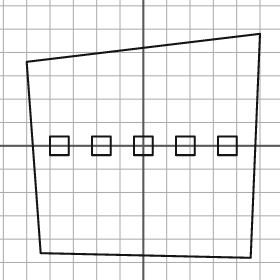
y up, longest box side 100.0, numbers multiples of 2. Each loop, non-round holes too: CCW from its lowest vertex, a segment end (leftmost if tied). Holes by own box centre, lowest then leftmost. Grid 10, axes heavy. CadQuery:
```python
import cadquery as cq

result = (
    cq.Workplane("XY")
    .moveTo(46.0, -48.0)
    .lineTo(50.0, 48.0)
    .lineTo(-50.0, 36.0)
    .lineTo(-44.0, -46.0)
    .close()
    .moveTo(-40.0, -4.0)
    .lineTo(-32.0, -4.0)
    .lineTo(-32.0, 4.0)
    .lineTo(-40.0, 4.0)
    .close()
    .moveTo(-22.0, -4.0)
    .lineTo(-14.0, -4.0)
    .lineTo(-14.0, 4.0)
    .lineTo(-22.0, 4.0)
    .close()
    .moveTo(-4.0, -4.0)
    .lineTo(4.0, -4.0)
    .lineTo(4.0, 4.0)
    .lineTo(-4.0, 4.0)
    .close()
    .moveTo(14.0, -4.0)
    .lineTo(22.0, -4.0)
    .lineTo(22.0, 4.0)
    .lineTo(14.0, 4.0)
    .close()
    .moveTo(32.0, -4.0)
    .lineTo(40.0, -4.0)
    .lineTo(40.0, 4.0)
    .lineTo(32.0, 4.0)
    .close()
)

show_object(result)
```